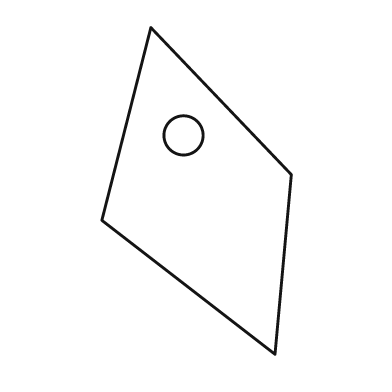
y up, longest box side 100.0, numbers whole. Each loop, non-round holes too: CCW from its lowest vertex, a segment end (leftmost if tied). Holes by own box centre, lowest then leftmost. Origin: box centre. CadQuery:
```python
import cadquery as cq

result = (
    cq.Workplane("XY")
    .moveTo(24.0, -50.0)
    .lineTo(29.0, 5.0)
    .lineTo(-14.0, 50.0)
    .lineTo(-29.0, -9.0)
    .close()
    .moveTo(-4.0, 17.0)
    .circle(6.0)
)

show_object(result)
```